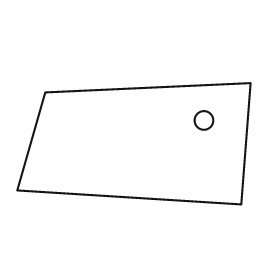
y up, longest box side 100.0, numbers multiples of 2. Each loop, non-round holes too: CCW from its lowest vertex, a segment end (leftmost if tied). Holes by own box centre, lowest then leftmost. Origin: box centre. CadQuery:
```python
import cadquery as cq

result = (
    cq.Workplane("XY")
    .moveTo(46.0, -26.0)
    .lineTo(50.0, 26.0)
    .lineTo(-38.0, 22.0)
    .lineTo(-50.0, -20.0)
    .close()
    .moveTo(30.0, 10.0)
    .circle(4.0)
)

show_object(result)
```